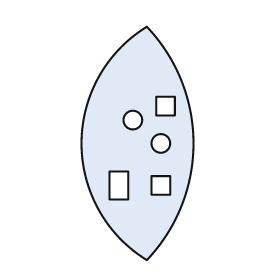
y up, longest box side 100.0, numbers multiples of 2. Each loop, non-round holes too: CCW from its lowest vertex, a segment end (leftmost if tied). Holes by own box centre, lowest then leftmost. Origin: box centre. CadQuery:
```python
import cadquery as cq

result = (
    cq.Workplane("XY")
    .moveTo(4.0, -50.0)
    .threePointArc((24.0, 0.0), (4.0, 50.0))
    .threePointArc((-24.0, 0.0), (4.0, -50.0))
    .close()
    .moveTo(-12.0, -24.0)
    .lineTo(-4.0, -24.0)
    .lineTo(-4.0, -12.0)
    .lineTo(-12.0, -12.0)
    .close()
    .moveTo(6.0, -22.0)
    .lineTo(14.0, -22.0)
    .lineTo(14.0, -14.0)
    .lineTo(6.0, -14.0)
    .close()
    .moveTo(10.0, 0.0)
    .circle(4.0)
    .moveTo(-2.0, 10.0)
    .circle(4.0)
    .moveTo(8.0, 12.0)
    .lineTo(16.0, 12.0)
    .lineTo(16.0, 20.0)
    .lineTo(8.0, 20.0)
    .close()
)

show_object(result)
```